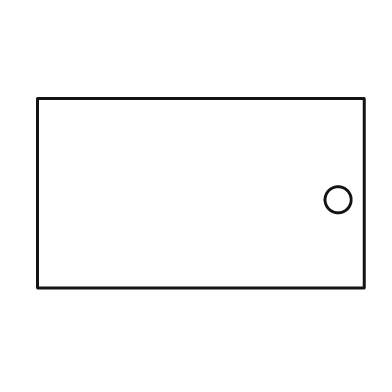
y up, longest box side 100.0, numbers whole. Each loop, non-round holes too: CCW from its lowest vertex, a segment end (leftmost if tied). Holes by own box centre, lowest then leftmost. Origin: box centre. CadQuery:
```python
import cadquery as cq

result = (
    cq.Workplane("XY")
    .moveTo(-50.0, -29.0)
    .lineTo(50.0, -29.0)
    .lineTo(50.0, 29.0)
    .lineTo(-50.0, 29.0)
    .close()
    .moveTo(42.0, -2.0)
    .circle(4.0)
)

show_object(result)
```